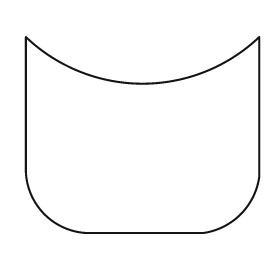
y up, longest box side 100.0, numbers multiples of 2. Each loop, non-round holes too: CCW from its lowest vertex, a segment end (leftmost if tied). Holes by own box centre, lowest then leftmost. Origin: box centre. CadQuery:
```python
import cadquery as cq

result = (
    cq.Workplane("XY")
    .moveTo(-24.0, -42.0)
    .lineTo(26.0, -42.0)
    .threePointArc((42.0, -34.0), (50.0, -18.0))
    .lineTo(50.0, 42.0)
    .threePointArc((0.0, 22.0), (-50.0, 42.0))
    .lineTo(-50.0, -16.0)
    .threePointArc((-42.0, -34.0), (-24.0, -42.0))
    .close()
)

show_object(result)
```